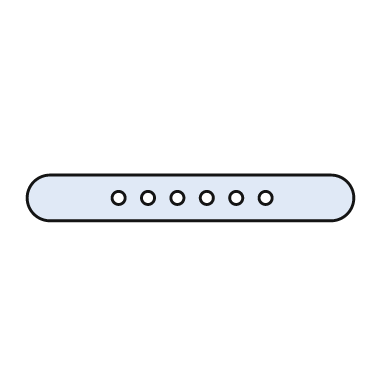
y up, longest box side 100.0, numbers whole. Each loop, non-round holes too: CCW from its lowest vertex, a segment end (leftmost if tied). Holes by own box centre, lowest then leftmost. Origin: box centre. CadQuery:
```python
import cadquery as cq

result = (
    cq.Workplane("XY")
    .moveTo(-43.0, -7.0)
    .lineTo(43.0, -7.0)
    .threePointArc((50.0, 0.0), (43.0, 7.0))
    .lineTo(-43.0, 7.0)
    .threePointArc((-50.0, 0.0), (-43.0, -7.0))
    .close()
    .moveTo(-22.0, 0.0)
    .circle(2.0)
    .moveTo(-13.0, 0.0)
    .circle(2.0)
    .moveTo(-4.0, 0.0)
    .circle(2.0)
    .moveTo(5.0, 0.0)
    .circle(2.0)
    .moveTo(14.0, 0.0)
    .circle(2.0)
    .moveTo(23.0, 0.0)
    .circle(2.0)
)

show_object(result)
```